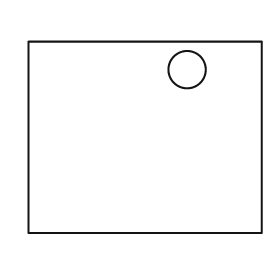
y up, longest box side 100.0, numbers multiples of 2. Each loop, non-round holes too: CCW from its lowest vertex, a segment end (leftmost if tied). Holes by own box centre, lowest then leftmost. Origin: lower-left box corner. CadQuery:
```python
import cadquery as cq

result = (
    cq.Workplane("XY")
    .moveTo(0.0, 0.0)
    .lineTo(100.0, 0.0)
    .lineTo(100.0, 82.0)
    .lineTo(0.0, 82.0)
    .close()
    .moveTo(68.0, 70.0)
    .circle(8.0)
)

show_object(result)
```